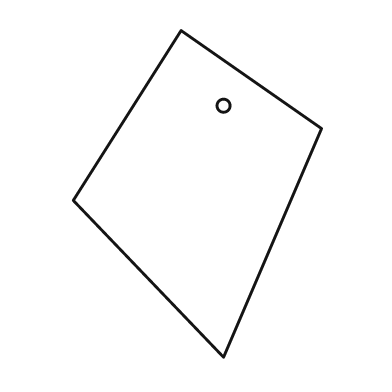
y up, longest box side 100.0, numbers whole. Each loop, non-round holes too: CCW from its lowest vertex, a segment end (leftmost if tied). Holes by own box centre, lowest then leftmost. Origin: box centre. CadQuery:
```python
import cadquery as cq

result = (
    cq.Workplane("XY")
    .moveTo(8.0, -50.0)
    .lineTo(38.0, 20.0)
    .lineTo(-5.0, 50.0)
    .lineTo(-38.0, -2.0)
    .close()
    .moveTo(8.0, 27.0)
    .circle(2.0)
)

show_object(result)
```